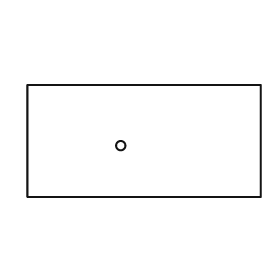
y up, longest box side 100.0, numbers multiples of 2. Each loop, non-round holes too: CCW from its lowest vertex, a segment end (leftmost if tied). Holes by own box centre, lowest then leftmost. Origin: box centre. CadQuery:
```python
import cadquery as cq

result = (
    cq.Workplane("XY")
    .moveTo(-50.0, -24.0)
    .lineTo(50.0, -24.0)
    .lineTo(50.0, 24.0)
    .lineTo(-50.0, 24.0)
    .close()
    .moveTo(-10.0, -2.0)
    .circle(2.0)
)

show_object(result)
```